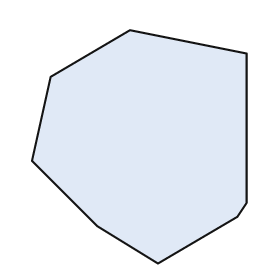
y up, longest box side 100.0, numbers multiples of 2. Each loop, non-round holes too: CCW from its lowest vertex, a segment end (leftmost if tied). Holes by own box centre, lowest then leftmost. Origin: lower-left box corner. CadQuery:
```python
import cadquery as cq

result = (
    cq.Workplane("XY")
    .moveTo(54.0, 0.0)
    .lineTo(88.0, 20.0)
    .lineTo(92.0, 26.0)
    .lineTo(92.0, 90.0)
    .lineTo(42.0, 100.0)
    .lineTo(8.0, 80.0)
    .lineTo(0.0, 44.0)
    .lineTo(28.0, 16.0)
    .close()
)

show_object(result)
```